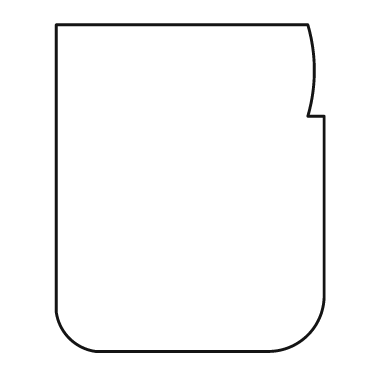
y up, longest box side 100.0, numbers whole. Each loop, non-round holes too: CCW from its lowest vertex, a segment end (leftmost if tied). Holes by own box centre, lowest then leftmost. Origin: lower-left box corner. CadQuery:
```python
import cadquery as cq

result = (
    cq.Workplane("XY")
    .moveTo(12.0, 0.0)
    .lineTo(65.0, 0.0)
    .threePointArc((77.0, 5.0), (82.0, 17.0))
    .lineTo(82.0, 72.0)
    .lineTo(77.0, 72.0)
    .threePointArc((79.0, 86.0), (77.0, 100.0))
    .lineTo(0.0, 100.0)
    .lineTo(0.0, 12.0)
    .threePointArc((4.0, 4.0), (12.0, 0.0))
    .close()
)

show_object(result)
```